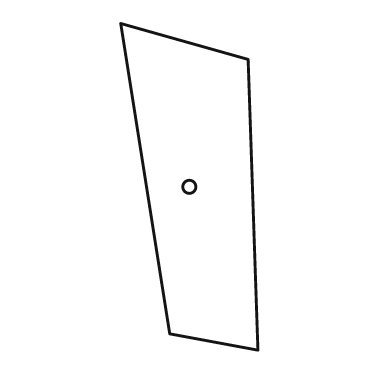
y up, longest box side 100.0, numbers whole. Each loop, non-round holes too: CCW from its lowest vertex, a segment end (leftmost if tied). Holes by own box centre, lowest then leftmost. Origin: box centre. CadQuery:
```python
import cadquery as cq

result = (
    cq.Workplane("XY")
    .moveTo(21.0, -50.0)
    .lineTo(18.0, 39.0)
    .lineTo(-21.0, 50.0)
    .lineTo(-6.0, -45.0)
    .close()
    .moveTo(0.0, 0.0)
    .circle(2.0)
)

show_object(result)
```